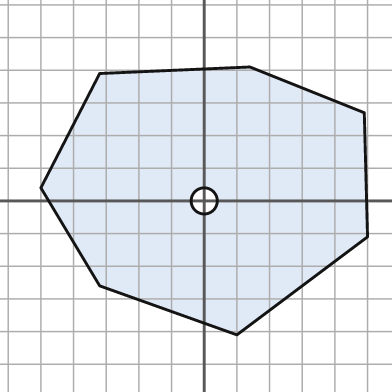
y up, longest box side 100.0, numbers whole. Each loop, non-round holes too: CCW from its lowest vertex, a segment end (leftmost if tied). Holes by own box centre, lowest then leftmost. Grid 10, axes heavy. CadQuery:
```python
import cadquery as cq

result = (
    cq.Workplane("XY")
    .moveTo(10.0, -41.0)
    .lineTo(50.0, -11.0)
    .lineTo(49.0, 27.0)
    .lineTo(14.0, 41.0)
    .lineTo(-32.0, 39.0)
    .lineTo(-50.0, 4.0)
    .lineTo(-32.0, -26.0)
    .close()
    .moveTo(0.0, 0.0)
    .circle(4.0)
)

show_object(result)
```